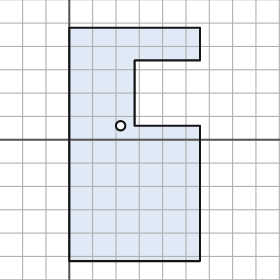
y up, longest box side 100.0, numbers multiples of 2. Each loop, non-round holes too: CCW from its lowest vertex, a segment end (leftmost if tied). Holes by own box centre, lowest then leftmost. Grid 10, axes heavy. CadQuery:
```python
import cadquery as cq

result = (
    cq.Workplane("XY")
    .moveTo(0.0, -52.0)
    .lineTo(56.0, -52.0)
    .lineTo(56.0, 6.0)
    .lineTo(28.0, 6.0)
    .lineTo(28.0, 34.0)
    .lineTo(56.0, 34.0)
    .lineTo(56.0, 48.0)
    .lineTo(0.0, 48.0)
    .close()
    .moveTo(22.0, 6.0)
    .circle(2.0)
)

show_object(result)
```